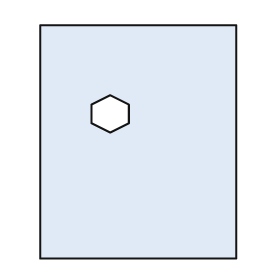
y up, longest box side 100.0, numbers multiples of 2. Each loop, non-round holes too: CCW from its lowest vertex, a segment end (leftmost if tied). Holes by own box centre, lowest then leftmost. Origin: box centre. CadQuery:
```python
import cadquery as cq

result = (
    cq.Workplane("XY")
    .moveTo(-42.0, -50.0)
    .lineTo(42.0, -50.0)
    .lineTo(42.0, 50.0)
    .lineTo(-42.0, 50.0)
    .close()
    .moveTo(-12.0, 4.0)
    .lineTo(-4.0, 8.0)
    .lineTo(-4.0, 16.0)
    .lineTo(-12.0, 20.0)
    .lineTo(-20.0, 16.0)
    .lineTo(-20.0, 8.0)
    .close()
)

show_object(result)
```